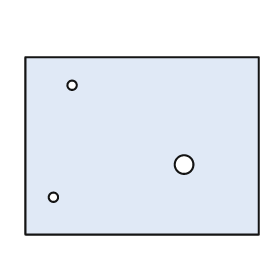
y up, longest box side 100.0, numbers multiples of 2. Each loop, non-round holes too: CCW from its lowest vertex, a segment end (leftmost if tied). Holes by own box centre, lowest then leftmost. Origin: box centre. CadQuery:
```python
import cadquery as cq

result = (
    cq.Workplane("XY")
    .moveTo(-50.0, -38.0)
    .lineTo(50.0, -38.0)
    .lineTo(50.0, 38.0)
    .lineTo(-50.0, 38.0)
    .close()
    .moveTo(-38.0, -22.0)
    .circle(2.0)
    .moveTo(18.0, -8.0)
    .circle(4.0)
    .moveTo(-30.0, 26.0)
    .circle(2.0)
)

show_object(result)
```